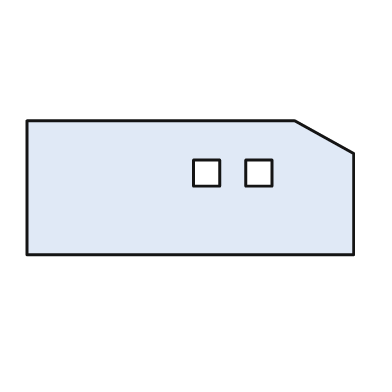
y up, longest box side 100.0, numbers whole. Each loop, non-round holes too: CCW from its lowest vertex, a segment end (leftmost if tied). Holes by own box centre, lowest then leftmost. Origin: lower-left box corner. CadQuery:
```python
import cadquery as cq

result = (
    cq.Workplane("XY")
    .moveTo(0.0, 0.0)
    .lineTo(100.0, 0.0)
    .lineTo(100.0, 31.0)
    .lineTo(82.0, 41.0)
    .lineTo(0.0, 41.0)
    .close()
    .moveTo(51.0, 21.0)
    .lineTo(59.0, 21.0)
    .lineTo(59.0, 29.0)
    .lineTo(51.0, 29.0)
    .close()
    .moveTo(67.0, 21.0)
    .lineTo(75.0, 21.0)
    .lineTo(75.0, 29.0)
    .lineTo(67.0, 29.0)
    .close()
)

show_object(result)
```